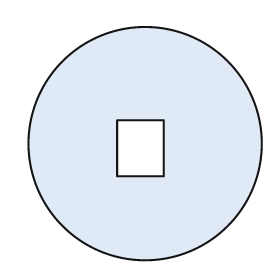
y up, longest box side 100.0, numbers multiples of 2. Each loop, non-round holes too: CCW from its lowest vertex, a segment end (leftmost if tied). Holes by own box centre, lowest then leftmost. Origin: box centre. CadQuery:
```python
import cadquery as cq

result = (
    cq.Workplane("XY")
    .moveTo(0.0, 0.0)
    .circle(50.0)
    .moveTo(-12.0, -14.0)
    .lineTo(8.0, -14.0)
    .lineTo(8.0, 10.0)
    .lineTo(-12.0, 10.0)
    .close()
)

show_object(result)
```